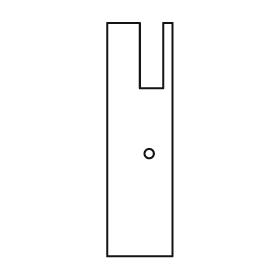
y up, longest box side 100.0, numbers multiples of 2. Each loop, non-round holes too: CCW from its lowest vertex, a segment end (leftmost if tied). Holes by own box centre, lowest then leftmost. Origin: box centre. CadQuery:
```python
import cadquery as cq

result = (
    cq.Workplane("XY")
    .moveTo(-14.0, -50.0)
    .lineTo(14.0, -50.0)
    .lineTo(14.0, 50.0)
    .lineTo(10.0, 50.0)
    .lineTo(10.0, 22.0)
    .lineTo(0.0, 22.0)
    .lineTo(0.0, 50.0)
    .lineTo(-14.0, 50.0)
    .close()
    .moveTo(4.0, -6.0)
    .circle(2.0)
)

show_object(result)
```